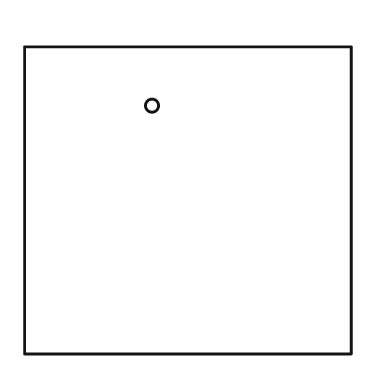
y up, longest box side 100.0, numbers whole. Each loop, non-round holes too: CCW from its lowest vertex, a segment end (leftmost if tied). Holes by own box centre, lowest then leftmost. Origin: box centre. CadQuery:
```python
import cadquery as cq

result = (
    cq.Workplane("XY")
    .moveTo(-50.0, -47.0)
    .lineTo(50.0, -47.0)
    .lineTo(50.0, 47.0)
    .lineTo(-50.0, 47.0)
    .close()
    .moveTo(-11.0, 29.0)
    .circle(2.0)
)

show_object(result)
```